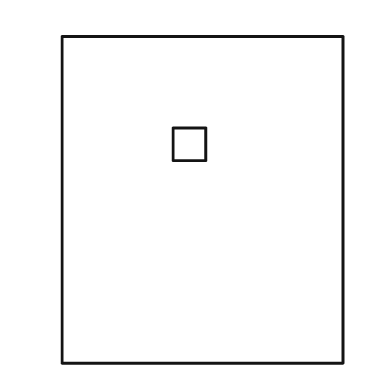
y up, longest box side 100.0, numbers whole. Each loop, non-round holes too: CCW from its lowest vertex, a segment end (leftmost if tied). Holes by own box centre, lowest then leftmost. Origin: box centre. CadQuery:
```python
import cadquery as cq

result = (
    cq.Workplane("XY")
    .moveTo(-43.0, -50.0)
    .lineTo(43.0, -50.0)
    .lineTo(43.0, 50.0)
    .lineTo(-43.0, 50.0)
    .close()
    .moveTo(-9.0, 12.0)
    .lineTo(1.0, 12.0)
    .lineTo(1.0, 22.0)
    .lineTo(-9.0, 22.0)
    .close()
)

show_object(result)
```